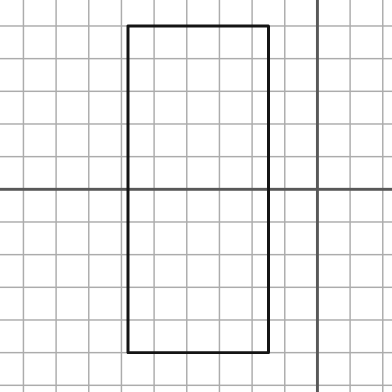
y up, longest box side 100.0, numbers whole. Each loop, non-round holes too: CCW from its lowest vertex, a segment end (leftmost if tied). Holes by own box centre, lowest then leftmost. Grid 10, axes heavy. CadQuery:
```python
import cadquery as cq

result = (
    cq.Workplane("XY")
    .moveTo(-58.0, -50.0)
    .lineTo(-15.0, -50.0)
    .lineTo(-15.0, 50.0)
    .lineTo(-58.0, 50.0)
    .close()
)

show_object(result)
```